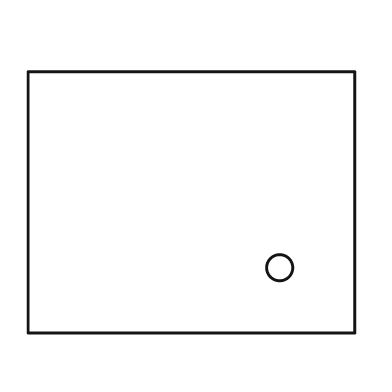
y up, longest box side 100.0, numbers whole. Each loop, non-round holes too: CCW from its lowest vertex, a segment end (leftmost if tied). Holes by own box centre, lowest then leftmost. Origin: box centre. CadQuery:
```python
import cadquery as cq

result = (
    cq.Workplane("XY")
    .moveTo(-50.0, -40.0)
    .lineTo(50.0, -40.0)
    .lineTo(50.0, 40.0)
    .lineTo(-50.0, 40.0)
    .close()
    .moveTo(27.0, -20.0)
    .circle(4.0)
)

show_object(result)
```